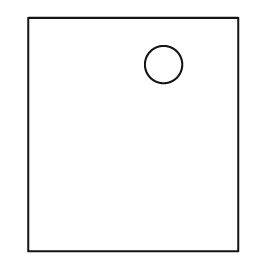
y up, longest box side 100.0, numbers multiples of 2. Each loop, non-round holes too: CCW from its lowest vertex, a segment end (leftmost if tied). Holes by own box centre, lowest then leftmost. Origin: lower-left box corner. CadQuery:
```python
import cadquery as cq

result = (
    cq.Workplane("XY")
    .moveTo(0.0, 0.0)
    .lineTo(90.0, 0.0)
    .lineTo(90.0, 100.0)
    .lineTo(0.0, 100.0)
    .close()
    .moveTo(58.0, 80.0)
    .circle(8.0)
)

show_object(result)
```